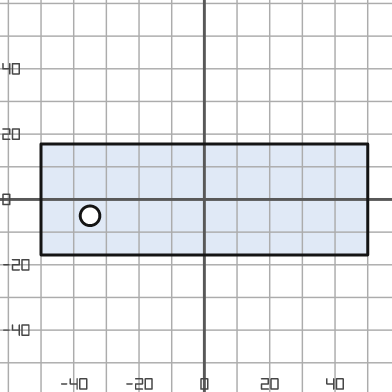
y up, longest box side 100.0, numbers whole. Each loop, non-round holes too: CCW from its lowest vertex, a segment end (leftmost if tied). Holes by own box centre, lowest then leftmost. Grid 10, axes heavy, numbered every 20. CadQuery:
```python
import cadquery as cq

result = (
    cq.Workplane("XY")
    .moveTo(-50.0, -17.0)
    .lineTo(50.0, -17.0)
    .lineTo(50.0, 17.0)
    .lineTo(-50.0, 17.0)
    .close()
    .moveTo(-35.0, -5.0)
    .circle(3.0)
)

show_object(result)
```